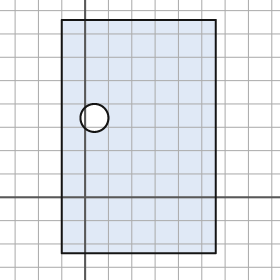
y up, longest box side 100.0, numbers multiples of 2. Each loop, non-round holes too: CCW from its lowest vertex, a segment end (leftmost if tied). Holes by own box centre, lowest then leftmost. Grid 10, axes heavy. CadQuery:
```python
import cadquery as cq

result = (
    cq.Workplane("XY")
    .moveTo(-10.0, -24.0)
    .lineTo(56.0, -24.0)
    .lineTo(56.0, 76.0)
    .lineTo(-10.0, 76.0)
    .close()
    .moveTo(4.0, 34.0)
    .circle(6.0)
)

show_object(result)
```